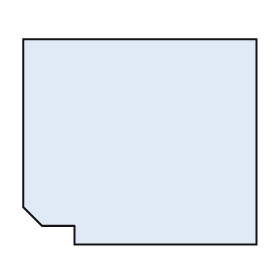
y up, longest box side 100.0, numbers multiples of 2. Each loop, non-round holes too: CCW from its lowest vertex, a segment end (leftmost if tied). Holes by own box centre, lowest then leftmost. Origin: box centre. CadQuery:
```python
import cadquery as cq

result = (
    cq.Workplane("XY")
    .moveTo(-28.0, -44.0)
    .lineTo(50.0, -44.0)
    .lineTo(50.0, 44.0)
    .lineTo(-50.0, 44.0)
    .lineTo(-50.0, -28.0)
    .lineTo(-42.0, -36.0)
    .lineTo(-28.0, -36.0)
    .close()
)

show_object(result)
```